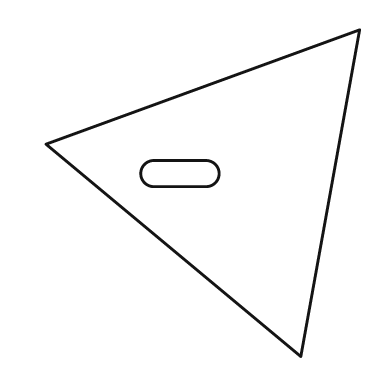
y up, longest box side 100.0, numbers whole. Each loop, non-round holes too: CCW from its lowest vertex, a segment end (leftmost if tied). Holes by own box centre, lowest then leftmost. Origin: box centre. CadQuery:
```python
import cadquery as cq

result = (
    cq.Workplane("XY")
    .moveTo(30.0, -50.0)
    .lineTo(48.0, 50.0)
    .lineTo(-48.0, 15.0)
    .close()
    .moveTo(-15.0, 2.0)
    .lineTo(1.0, 2.0)
    .threePointArc((5.0, 6.0), (1.0, 10.0))
    .lineTo(-15.0, 10.0)
    .threePointArc((-19.0, 6.0), (-15.0, 2.0))
    .close()
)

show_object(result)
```